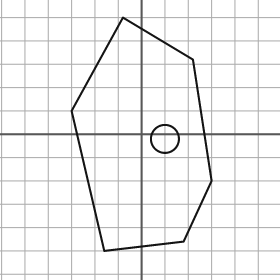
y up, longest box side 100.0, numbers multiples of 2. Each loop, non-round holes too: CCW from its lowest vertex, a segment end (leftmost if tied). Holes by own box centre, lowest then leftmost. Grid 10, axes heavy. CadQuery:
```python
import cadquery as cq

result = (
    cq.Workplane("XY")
    .moveTo(-16.0, -50.0)
    .lineTo(18.0, -46.0)
    .lineTo(30.0, -20.0)
    .lineTo(22.0, 32.0)
    .lineTo(-8.0, 50.0)
    .lineTo(-30.0, 10.0)
    .close()
    .moveTo(10.0, -2.0)
    .circle(6.0)
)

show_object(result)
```